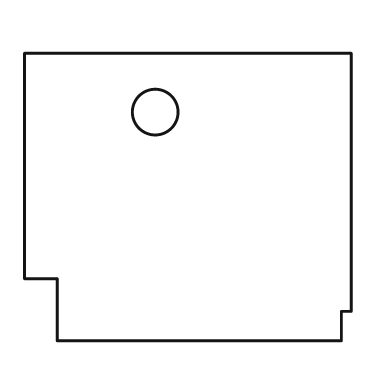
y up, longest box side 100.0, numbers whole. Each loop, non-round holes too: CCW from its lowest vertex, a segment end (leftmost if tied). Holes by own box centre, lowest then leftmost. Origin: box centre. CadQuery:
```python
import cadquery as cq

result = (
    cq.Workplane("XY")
    .moveTo(-40.0, -44.0)
    .lineTo(47.0, -44.0)
    .lineTo(47.0, -35.0)
    .lineTo(50.0, -35.0)
    .lineTo(50.0, 44.0)
    .lineTo(-50.0, 44.0)
    .lineTo(-50.0, -25.0)
    .lineTo(-40.0, -25.0)
    .close()
    .moveTo(-10.0, 26.0)
    .circle(7.0)
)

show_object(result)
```